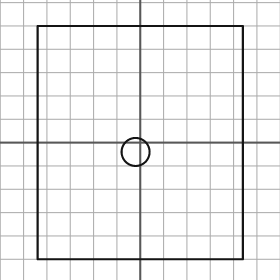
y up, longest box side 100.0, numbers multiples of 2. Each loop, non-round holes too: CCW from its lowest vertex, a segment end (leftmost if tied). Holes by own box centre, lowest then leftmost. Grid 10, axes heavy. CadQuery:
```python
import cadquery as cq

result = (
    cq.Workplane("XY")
    .moveTo(-44.0, -50.0)
    .lineTo(44.0, -50.0)
    .lineTo(44.0, 50.0)
    .lineTo(-44.0, 50.0)
    .close()
    .moveTo(-2.0, -4.0)
    .circle(6.0)
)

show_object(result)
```